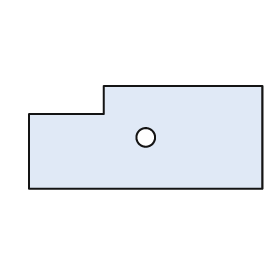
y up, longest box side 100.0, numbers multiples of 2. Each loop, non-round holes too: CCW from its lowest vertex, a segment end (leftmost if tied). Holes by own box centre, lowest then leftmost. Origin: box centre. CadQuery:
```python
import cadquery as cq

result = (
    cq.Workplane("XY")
    .moveTo(-50.0, -22.0)
    .lineTo(50.0, -22.0)
    .lineTo(50.0, 22.0)
    .lineTo(-18.0, 22.0)
    .lineTo(-18.0, 10.0)
    .lineTo(-50.0, 10.0)
    .close()
    .moveTo(0.0, 0.0)
    .circle(4.0)
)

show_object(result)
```